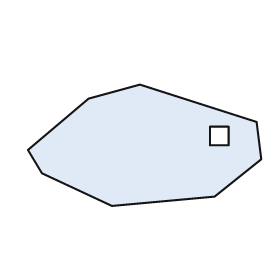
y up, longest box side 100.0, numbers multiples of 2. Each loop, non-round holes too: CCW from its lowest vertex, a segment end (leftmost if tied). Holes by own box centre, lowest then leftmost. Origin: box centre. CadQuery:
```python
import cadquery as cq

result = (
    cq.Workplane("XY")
    .moveTo(-14.0, -26.0)
    .lineTo(30.0, -22.0)
    .lineTo(50.0, -6.0)
    .lineTo(48.0, 10.0)
    .lineTo(-2.0, 26.0)
    .lineTo(-24.0, 20.0)
    .lineTo(-50.0, -2.0)
    .lineTo(-44.0, -12.0)
    .close()
    .moveTo(28.0, 0.0)
    .lineTo(36.0, 0.0)
    .lineTo(36.0, 8.0)
    .lineTo(28.0, 8.0)
    .close()
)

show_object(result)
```